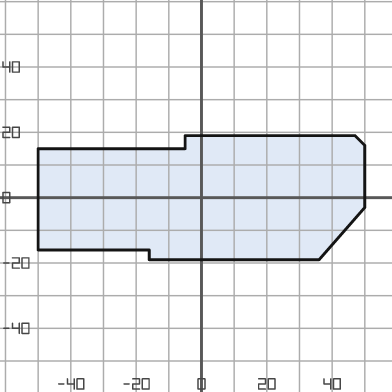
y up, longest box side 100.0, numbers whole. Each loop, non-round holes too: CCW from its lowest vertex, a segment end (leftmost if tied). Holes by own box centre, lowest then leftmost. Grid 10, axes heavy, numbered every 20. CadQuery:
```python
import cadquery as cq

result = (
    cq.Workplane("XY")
    .moveTo(-16.0, -19.0)
    .lineTo(36.0, -19.0)
    .lineTo(50.0, -3.0)
    .lineTo(50.0, 16.0)
    .lineTo(47.0, 19.0)
    .lineTo(-5.0, 19.0)
    .lineTo(-5.0, 15.0)
    .lineTo(-50.0, 15.0)
    .lineTo(-50.0, -16.0)
    .lineTo(-16.0, -16.0)
    .close()
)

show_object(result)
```